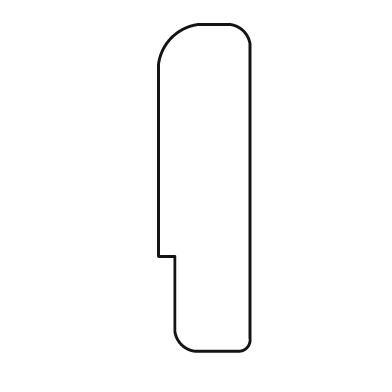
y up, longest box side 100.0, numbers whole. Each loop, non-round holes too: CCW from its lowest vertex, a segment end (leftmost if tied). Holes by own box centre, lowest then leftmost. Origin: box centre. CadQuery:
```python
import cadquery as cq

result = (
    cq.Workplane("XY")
    .moveTo(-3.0, -50.0)
    .lineTo(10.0, -50.0)
    .threePointArc((13.0, -49.0), (14.0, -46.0))
    .lineTo(14.0, 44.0)
    .threePointArc((12.0, 48.0), (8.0, 50.0))
    .lineTo(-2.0, 50.0)
    .threePointArc((-10.0, 46.0), (-14.0, 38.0))
    .lineTo(-14.0, -21.0)
    .lineTo(-9.0, -21.0)
    .lineTo(-9.0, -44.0)
    .threePointArc((-7.0, -48.0), (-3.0, -50.0))
    .close()
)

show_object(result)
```